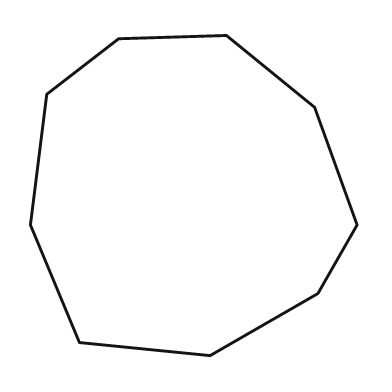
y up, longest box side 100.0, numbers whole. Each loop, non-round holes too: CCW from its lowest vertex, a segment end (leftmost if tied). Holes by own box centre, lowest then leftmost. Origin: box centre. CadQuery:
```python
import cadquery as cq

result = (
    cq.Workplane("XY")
    .moveTo(5.0, -49.0)
    .lineTo(38.0, -30.0)
    .lineTo(50.0, -9.0)
    .lineTo(37.0, 27.0)
    .lineTo(10.0, 49.0)
    .lineTo(-23.0, 48.0)
    .lineTo(-45.0, 31.0)
    .lineTo(-50.0, -9.0)
    .lineTo(-35.0, -45.0)
    .close()
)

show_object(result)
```